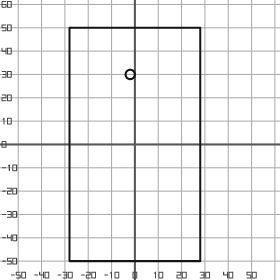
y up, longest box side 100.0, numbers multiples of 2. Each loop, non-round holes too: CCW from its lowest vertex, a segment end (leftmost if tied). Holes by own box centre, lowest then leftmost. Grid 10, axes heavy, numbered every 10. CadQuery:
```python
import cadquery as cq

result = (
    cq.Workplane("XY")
    .moveTo(-28.0, -50.0)
    .lineTo(28.0, -50.0)
    .lineTo(28.0, 50.0)
    .lineTo(-28.0, 50.0)
    .close()
    .moveTo(-2.0, 30.0)
    .circle(2.0)
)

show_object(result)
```